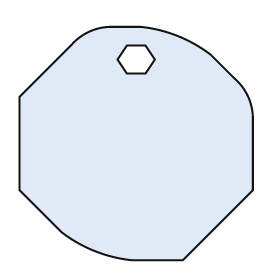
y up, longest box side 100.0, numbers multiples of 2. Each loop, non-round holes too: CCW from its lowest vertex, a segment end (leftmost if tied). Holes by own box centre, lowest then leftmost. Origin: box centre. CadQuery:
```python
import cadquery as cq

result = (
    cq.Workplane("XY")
    .moveTo(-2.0, -50.0)
    .lineTo(20.0, -50.0)
    .lineTo(50.0, -20.0)
    .lineTo(50.0, 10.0)
    .threePointArc((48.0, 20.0), (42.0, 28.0))
    .lineTo(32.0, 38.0)
    .threePointArc((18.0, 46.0), (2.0, 50.0))
    .lineTo(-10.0, 50.0)
    .threePointArc((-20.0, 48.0), (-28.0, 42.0))
    .lineTo(-50.0, 20.0)
    .lineTo(-50.0, -20.0)
    .lineTo(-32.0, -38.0)
    .threePointArc((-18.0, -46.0), (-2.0, -50.0))
    .close()
    .moveTo(-4.0, 30.0)
    .lineTo(4.0, 30.0)
    .lineTo(8.0, 36.0)
    .lineTo(4.0, 42.0)
    .lineTo(-4.0, 42.0)
    .lineTo(-8.0, 36.0)
    .close()
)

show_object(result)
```